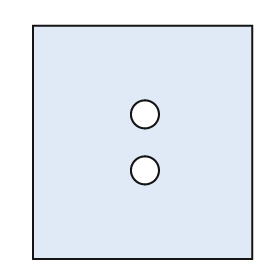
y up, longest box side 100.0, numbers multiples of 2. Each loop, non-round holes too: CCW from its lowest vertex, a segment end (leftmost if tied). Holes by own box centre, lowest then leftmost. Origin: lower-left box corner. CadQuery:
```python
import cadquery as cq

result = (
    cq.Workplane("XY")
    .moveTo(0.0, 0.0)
    .lineTo(94.0, 0.0)
    .lineTo(94.0, 100.0)
    .lineTo(0.0, 100.0)
    .close()
    .moveTo(48.0, 38.0)
    .circle(6.0)
    .moveTo(48.0, 62.0)
    .circle(6.0)
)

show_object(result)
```